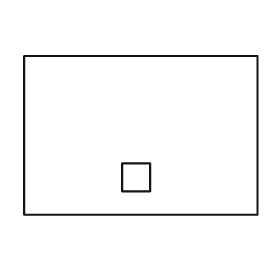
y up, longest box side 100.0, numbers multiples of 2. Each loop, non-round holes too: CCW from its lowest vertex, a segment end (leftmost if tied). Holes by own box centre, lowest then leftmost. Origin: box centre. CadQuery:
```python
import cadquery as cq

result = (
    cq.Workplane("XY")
    .moveTo(-50.0, -34.0)
    .lineTo(50.0, -34.0)
    .lineTo(50.0, 34.0)
    .lineTo(-50.0, 34.0)
    .close()
    .moveTo(-8.0, -24.0)
    .lineTo(4.0, -24.0)
    .lineTo(4.0, -12.0)
    .lineTo(-8.0, -12.0)
    .close()
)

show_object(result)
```